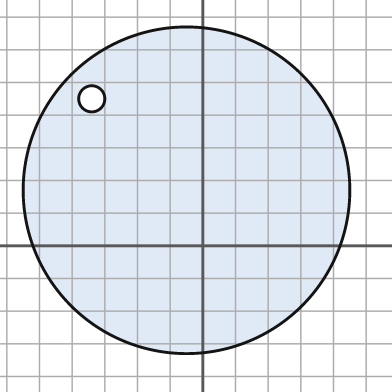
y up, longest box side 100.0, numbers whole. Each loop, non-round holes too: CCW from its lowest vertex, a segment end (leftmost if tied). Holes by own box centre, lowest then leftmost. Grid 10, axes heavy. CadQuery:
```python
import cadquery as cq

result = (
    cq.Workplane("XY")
    .moveTo(-5.0, 17.0)
    .circle(50.0)
    .moveTo(-34.0, 45.0)
    .circle(4.0)
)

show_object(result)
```